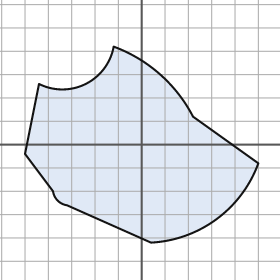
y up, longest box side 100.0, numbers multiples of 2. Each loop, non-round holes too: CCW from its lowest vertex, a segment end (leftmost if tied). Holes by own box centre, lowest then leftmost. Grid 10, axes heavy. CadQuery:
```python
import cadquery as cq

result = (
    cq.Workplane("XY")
    .moveTo(4.0, -42.0)
    .threePointArc((32.0, -32.0), (50.0, -8.0))
    .lineTo(22.0, 12.0)
    .threePointArc((8.0, 30.0), (-12.0, 42.0))
    .threePointArc((-24.0, 26.0), (-44.0, 26.0))
    .lineTo(-50.0, -4.0)
    .lineTo(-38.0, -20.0)
    .threePointArc((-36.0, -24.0), (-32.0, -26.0))
    .close()
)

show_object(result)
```